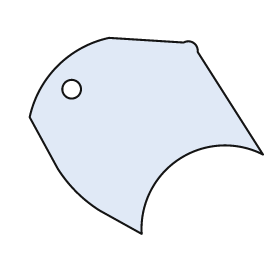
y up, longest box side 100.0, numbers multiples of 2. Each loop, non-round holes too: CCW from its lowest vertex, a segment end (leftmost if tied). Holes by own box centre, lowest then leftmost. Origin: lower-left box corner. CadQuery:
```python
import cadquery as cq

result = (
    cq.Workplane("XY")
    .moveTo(48.0, 0.0)
    .threePointArc((64.0, 32.0), (100.0, 34.0))
    .lineTo(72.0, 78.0)
    .threePointArc((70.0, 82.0), (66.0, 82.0))
    .lineTo(34.0, 84.0)
    .threePointArc((12.0, 72.0), (0.0, 50.0))
    .lineTo(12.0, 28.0)
    .threePointArc((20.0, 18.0), (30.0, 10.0))
    .close()
    .moveTo(18.0, 62.0)
    .circle(4.0)
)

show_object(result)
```